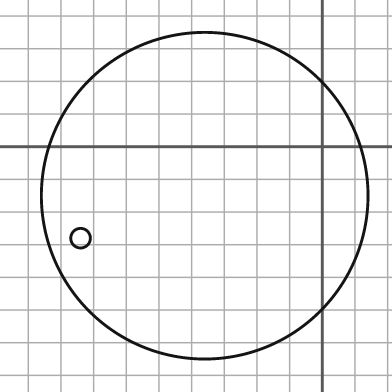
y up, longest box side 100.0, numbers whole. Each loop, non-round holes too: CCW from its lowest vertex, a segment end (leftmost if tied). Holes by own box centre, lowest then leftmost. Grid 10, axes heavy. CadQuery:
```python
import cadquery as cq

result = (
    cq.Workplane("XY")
    .moveTo(-36.0, -15.0)
    .circle(50.0)
    .moveTo(-74.0, -28.0)
    .circle(3.0)
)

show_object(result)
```